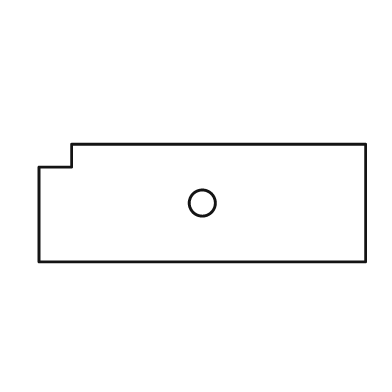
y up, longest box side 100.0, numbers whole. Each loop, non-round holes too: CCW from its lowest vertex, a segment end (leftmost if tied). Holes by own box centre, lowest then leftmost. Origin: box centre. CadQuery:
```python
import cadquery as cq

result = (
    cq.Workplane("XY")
    .moveTo(-50.0, -18.0)
    .lineTo(50.0, -18.0)
    .lineTo(50.0, 18.0)
    .lineTo(-40.0, 18.0)
    .lineTo(-40.0, 11.0)
    .lineTo(-50.0, 11.0)
    .close()
    .moveTo(0.0, 0.0)
    .circle(4.0)
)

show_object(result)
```